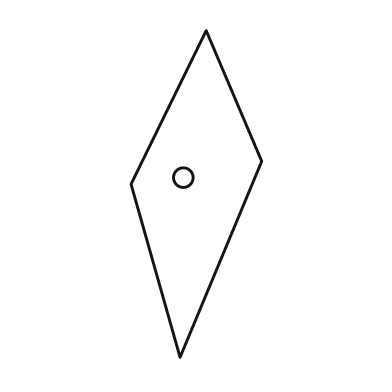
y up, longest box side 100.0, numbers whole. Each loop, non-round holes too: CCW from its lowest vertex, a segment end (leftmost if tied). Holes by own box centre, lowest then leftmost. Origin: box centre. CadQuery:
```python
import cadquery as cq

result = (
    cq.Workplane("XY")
    .moveTo(-5.0, -50.0)
    .lineTo(20.0, 10.0)
    .lineTo(3.0, 50.0)
    .lineTo(-20.0, 3.0)
    .close()
    .moveTo(-4.0, 5.0)
    .circle(3.0)
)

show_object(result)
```